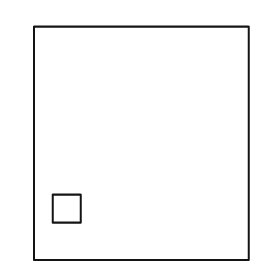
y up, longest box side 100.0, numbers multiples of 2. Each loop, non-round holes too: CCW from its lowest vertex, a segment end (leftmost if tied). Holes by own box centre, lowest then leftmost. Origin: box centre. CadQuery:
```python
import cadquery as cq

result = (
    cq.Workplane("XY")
    .moveTo(-46.0, -50.0)
    .lineTo(46.0, -50.0)
    .lineTo(46.0, 50.0)
    .lineTo(-46.0, 50.0)
    .close()
    .moveTo(-38.0, -34.0)
    .lineTo(-26.0, -34.0)
    .lineTo(-26.0, -22.0)
    .lineTo(-38.0, -22.0)
    .close()
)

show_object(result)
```